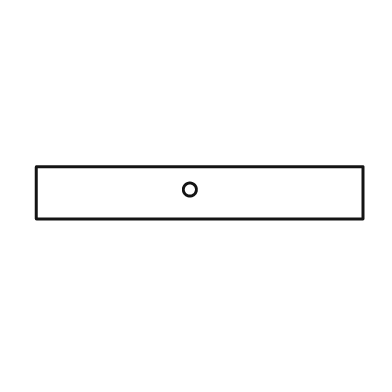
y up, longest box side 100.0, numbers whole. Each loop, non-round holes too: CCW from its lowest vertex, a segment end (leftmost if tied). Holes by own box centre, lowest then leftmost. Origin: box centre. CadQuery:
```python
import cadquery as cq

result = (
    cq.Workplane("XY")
    .moveTo(-50.0, -8.0)
    .lineTo(50.0, -8.0)
    .lineTo(50.0, 8.0)
    .lineTo(-50.0, 8.0)
    .close()
    .moveTo(-3.0, 1.0)
    .circle(2.0)
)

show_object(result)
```